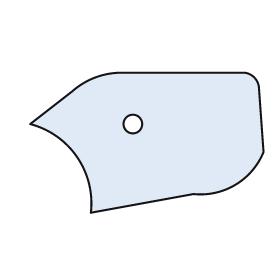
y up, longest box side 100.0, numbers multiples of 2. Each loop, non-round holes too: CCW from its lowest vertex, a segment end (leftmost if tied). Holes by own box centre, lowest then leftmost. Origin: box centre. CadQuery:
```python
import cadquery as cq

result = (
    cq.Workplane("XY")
    .moveTo(-24.0, -30.0)
    .lineTo(20.0, -22.0)
    .threePointArc((38.0, -18.0), (50.0, -4.0))
    .lineTo(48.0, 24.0)
    .threePointArc((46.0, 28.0), (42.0, 30.0))
    .lineTo(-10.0, 30.0)
    .threePointArc((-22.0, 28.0), (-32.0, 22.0))
    .lineTo(-50.0, 8.0)
    .threePointArc((-30.0, -6.0), (-24.0, -30.0))
    .close()
    .moveTo(-6.0, 8.0)
    .circle(4.0)
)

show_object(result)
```